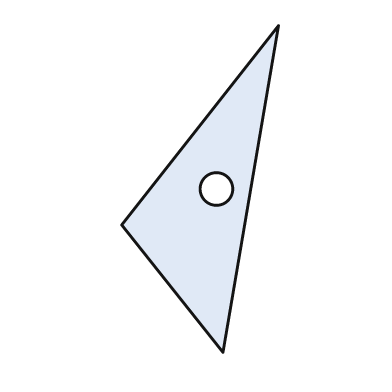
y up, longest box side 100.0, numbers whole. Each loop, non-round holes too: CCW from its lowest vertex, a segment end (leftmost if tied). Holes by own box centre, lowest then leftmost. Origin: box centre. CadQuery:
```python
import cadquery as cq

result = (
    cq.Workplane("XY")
    .moveTo(7.0, -50.0)
    .lineTo(24.0, 50.0)
    .lineTo(-24.0, -11.0)
    .close()
    .moveTo(5.0, 0.0)
    .circle(5.0)
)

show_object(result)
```